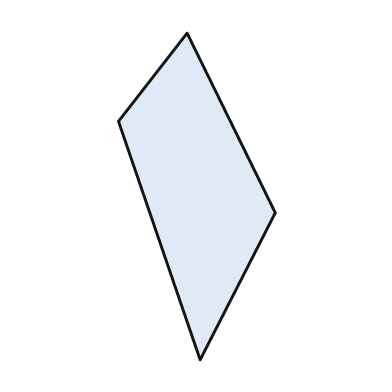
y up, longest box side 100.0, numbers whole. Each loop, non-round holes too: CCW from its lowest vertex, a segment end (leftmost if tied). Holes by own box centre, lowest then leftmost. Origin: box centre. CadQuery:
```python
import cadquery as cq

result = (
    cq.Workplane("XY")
    .moveTo(1.0, -50.0)
    .lineTo(24.0, -5.0)
    .lineTo(-3.0, 50.0)
    .lineTo(-24.0, 23.0)
    .close()
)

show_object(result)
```